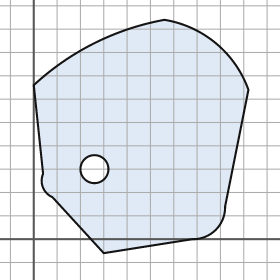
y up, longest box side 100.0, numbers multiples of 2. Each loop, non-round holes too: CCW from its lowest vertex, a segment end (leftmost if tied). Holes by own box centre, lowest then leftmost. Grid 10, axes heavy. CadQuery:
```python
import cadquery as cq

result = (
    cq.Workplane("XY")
    .moveTo(30.0, -6.0)
    .lineTo(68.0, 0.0)
    .threePointArc((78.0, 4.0), (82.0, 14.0))
    .lineTo(92.0, 64.0)
    .threePointArc((78.0, 84.0), (56.0, 94.0))
    .threePointArc((26.0, 84.0), (0.0, 66.0))
    .lineTo(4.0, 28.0)
    .threePointArc((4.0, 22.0), (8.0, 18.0))
    .close()
    .moveTo(26.0, 30.0)
    .circle(6.0)
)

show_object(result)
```